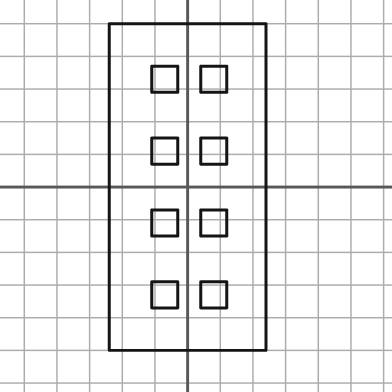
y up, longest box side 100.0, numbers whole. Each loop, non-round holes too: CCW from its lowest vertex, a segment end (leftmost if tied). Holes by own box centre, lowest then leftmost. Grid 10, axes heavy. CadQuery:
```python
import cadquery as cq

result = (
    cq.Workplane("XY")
    .moveTo(-24.0, -50.0)
    .lineTo(24.0, -50.0)
    .lineTo(24.0, 50.0)
    .lineTo(-24.0, 50.0)
    .close()
    .moveTo(-11.0, -37.0)
    .lineTo(-3.0, -37.0)
    .lineTo(-3.0, -29.0)
    .lineTo(-11.0, -29.0)
    .close()
    .moveTo(4.0, -37.0)
    .lineTo(12.0, -37.0)
    .lineTo(12.0, -29.0)
    .lineTo(4.0, -29.0)
    .close()
    .moveTo(-11.0, -15.0)
    .lineTo(-3.0, -15.0)
    .lineTo(-3.0, -7.0)
    .lineTo(-11.0, -7.0)
    .close()
    .moveTo(4.0, -15.0)
    .lineTo(12.0, -15.0)
    .lineTo(12.0, -7.0)
    .lineTo(4.0, -7.0)
    .close()
    .moveTo(-11.0, 7.0)
    .lineTo(-3.0, 7.0)
    .lineTo(-3.0, 15.0)
    .lineTo(-11.0, 15.0)
    .close()
    .moveTo(4.0, 7.0)
    .lineTo(12.0, 7.0)
    .lineTo(12.0, 15.0)
    .lineTo(4.0, 15.0)
    .close()
    .moveTo(-11.0, 29.0)
    .lineTo(-3.0, 29.0)
    .lineTo(-3.0, 37.0)
    .lineTo(-11.0, 37.0)
    .close()
    .moveTo(4.0, 29.0)
    .lineTo(12.0, 29.0)
    .lineTo(12.0, 37.0)
    .lineTo(4.0, 37.0)
    .close()
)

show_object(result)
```